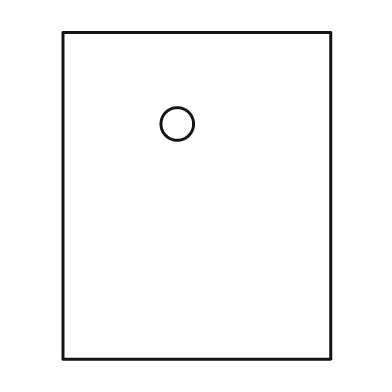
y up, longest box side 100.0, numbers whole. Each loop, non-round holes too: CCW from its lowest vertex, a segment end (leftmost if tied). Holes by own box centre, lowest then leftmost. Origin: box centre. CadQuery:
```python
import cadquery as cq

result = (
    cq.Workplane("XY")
    .moveTo(-41.0, -50.0)
    .lineTo(41.0, -50.0)
    .lineTo(41.0, 50.0)
    .lineTo(-41.0, 50.0)
    .close()
    .moveTo(-6.0, 22.0)
    .circle(5.0)
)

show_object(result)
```